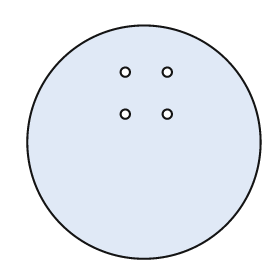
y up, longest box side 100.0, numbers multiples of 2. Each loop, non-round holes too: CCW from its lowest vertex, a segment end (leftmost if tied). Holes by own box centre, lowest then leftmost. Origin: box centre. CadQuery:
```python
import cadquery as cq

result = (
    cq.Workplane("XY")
    .moveTo(0.0, 0.0)
    .circle(50.0)
    .moveTo(-8.0, 12.0)
    .circle(2.0)
    .moveTo(10.0, 12.0)
    .circle(2.0)
    .moveTo(-8.0, 30.0)
    .circle(2.0)
    .moveTo(10.0, 30.0)
    .circle(2.0)
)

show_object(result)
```